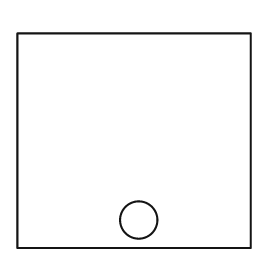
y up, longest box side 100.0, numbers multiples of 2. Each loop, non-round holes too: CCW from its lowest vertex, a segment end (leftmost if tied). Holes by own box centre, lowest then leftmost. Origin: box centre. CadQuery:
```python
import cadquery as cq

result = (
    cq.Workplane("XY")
    .moveTo(-50.0, -46.0)
    .lineTo(50.0, -46.0)
    .lineTo(50.0, 46.0)
    .lineTo(-50.0, 46.0)
    .close()
    .moveTo(2.0, -34.0)
    .circle(8.0)
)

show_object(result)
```